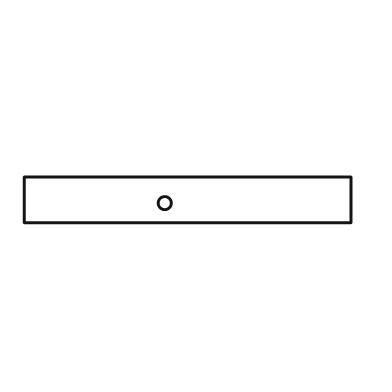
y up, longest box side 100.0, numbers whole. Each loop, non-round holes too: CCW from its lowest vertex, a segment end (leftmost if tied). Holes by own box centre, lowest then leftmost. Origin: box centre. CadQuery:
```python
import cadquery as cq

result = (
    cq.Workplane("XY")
    .moveTo(-50.0, -7.0)
    .lineTo(50.0, -7.0)
    .lineTo(50.0, 7.0)
    .lineTo(-50.0, 7.0)
    .close()
    .moveTo(-7.0, -1.0)
    .circle(2.0)
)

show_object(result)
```